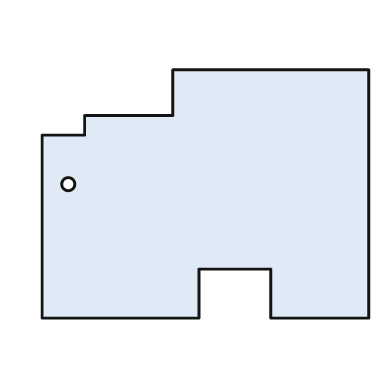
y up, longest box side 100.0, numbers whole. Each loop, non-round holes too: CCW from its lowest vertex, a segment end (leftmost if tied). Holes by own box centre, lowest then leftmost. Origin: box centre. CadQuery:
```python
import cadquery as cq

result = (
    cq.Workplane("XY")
    .moveTo(-50.0, -38.0)
    .lineTo(-2.0, -38.0)
    .lineTo(-2.0, -23.0)
    .lineTo(20.0, -23.0)
    .lineTo(20.0, -38.0)
    .lineTo(50.0, -38.0)
    .lineTo(50.0, 38.0)
    .lineTo(-10.0, 38.0)
    .lineTo(-10.0, 24.0)
    .lineTo(-37.0, 24.0)
    .lineTo(-37.0, 18.0)
    .lineTo(-50.0, 18.0)
    .close()
    .moveTo(-42.0, 3.0)
    .circle(2.0)
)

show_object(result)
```